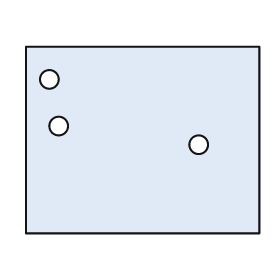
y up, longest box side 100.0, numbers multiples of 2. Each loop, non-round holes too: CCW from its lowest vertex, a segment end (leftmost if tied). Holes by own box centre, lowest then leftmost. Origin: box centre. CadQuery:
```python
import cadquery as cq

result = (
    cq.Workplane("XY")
    .moveTo(-50.0, -40.0)
    .lineTo(50.0, -40.0)
    .lineTo(50.0, 40.0)
    .lineTo(-50.0, 40.0)
    .close()
    .moveTo(24.0, -2.0)
    .circle(4.0)
    .moveTo(-36.0, 6.0)
    .circle(4.0)
    .moveTo(-40.0, 26.0)
    .circle(4.0)
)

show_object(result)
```